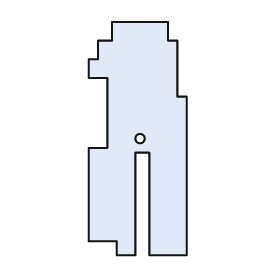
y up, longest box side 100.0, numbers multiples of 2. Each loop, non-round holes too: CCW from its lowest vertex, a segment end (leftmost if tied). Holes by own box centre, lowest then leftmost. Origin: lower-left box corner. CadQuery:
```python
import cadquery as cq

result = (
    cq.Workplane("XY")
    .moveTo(12.0, 0.0)
    .lineTo(20.0, 0.0)
    .lineTo(20.0, 44.0)
    .lineTo(26.0, 44.0)
    .lineTo(26.0, 0.0)
    .lineTo(42.0, 0.0)
    .lineTo(42.0, 68.0)
    .lineTo(38.0, 68.0)
    .lineTo(38.0, 92.0)
    .lineTo(34.0, 92.0)
    .lineTo(34.0, 100.0)
    .lineTo(10.0, 100.0)
    .lineTo(10.0, 92.0)
    .lineTo(4.0, 92.0)
    .lineTo(4.0, 84.0)
    .lineTo(0.0, 84.0)
    .lineTo(0.0, 76.0)
    .lineTo(8.0, 76.0)
    .lineTo(8.0, 46.0)
    .lineTo(0.0, 46.0)
    .lineTo(0.0, 6.0)
    .lineTo(12.0, 6.0)
    .close()
    .moveTo(22.0, 50.0)
    .circle(2.0)
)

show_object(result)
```